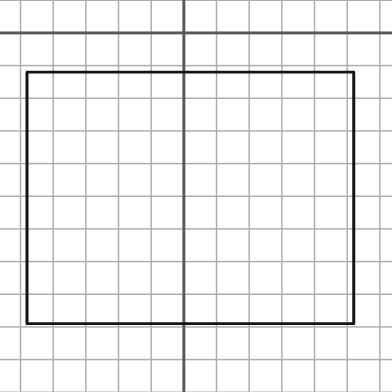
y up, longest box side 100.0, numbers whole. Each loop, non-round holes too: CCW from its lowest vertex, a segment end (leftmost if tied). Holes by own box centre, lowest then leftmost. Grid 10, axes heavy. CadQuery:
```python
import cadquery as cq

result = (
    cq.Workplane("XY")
    .moveTo(-48.0, -89.0)
    .lineTo(52.0, -89.0)
    .lineTo(52.0, -12.0)
    .lineTo(-48.0, -12.0)
    .close()
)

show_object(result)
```